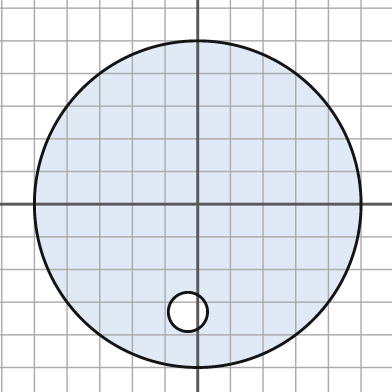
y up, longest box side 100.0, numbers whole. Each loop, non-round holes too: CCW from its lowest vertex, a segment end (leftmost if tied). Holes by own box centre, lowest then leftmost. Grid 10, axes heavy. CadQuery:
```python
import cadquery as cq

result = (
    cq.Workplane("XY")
    .moveTo(0.0, 0.0)
    .circle(50.0)
    .moveTo(-3.0, -33.0)
    .circle(6.0)
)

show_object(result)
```